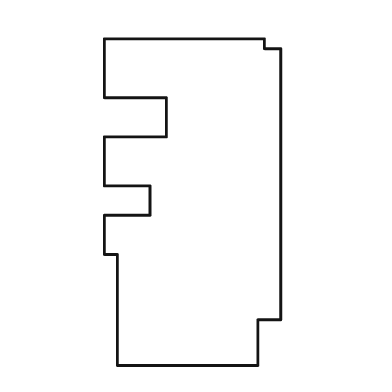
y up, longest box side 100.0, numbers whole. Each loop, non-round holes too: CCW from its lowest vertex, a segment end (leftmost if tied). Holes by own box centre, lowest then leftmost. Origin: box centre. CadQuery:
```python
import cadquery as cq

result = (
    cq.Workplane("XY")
    .moveTo(-23.0, -50.0)
    .lineTo(20.0, -50.0)
    .lineTo(20.0, -36.0)
    .lineTo(27.0, -36.0)
    .lineTo(27.0, 47.0)
    .lineTo(22.0, 47.0)
    .lineTo(22.0, 50.0)
    .lineTo(-27.0, 50.0)
    .lineTo(-27.0, 32.0)
    .lineTo(-8.0, 32.0)
    .lineTo(-8.0, 20.0)
    .lineTo(-27.0, 20.0)
    .lineTo(-27.0, 5.0)
    .lineTo(-13.0, 5.0)
    .lineTo(-13.0, -4.0)
    .lineTo(-27.0, -4.0)
    .lineTo(-27.0, -16.0)
    .lineTo(-23.0, -16.0)
    .close()
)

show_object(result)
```